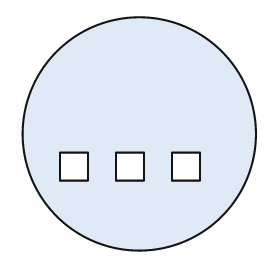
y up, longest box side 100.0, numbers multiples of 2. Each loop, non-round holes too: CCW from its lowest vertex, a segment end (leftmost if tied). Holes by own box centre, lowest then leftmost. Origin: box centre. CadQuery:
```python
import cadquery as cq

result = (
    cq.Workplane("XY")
    .moveTo(0.0, 0.0)
    .circle(50.0)
    .moveTo(-34.0, -20.0)
    .lineTo(-22.0, -20.0)
    .lineTo(-22.0, -8.0)
    .lineTo(-34.0, -8.0)
    .close()
    .moveTo(-10.0, -20.0)
    .lineTo(2.0, -20.0)
    .lineTo(2.0, -8.0)
    .lineTo(-10.0, -8.0)
    .close()
    .moveTo(14.0, -20.0)
    .lineTo(26.0, -20.0)
    .lineTo(26.0, -8.0)
    .lineTo(14.0, -8.0)
    .close()
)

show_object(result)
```